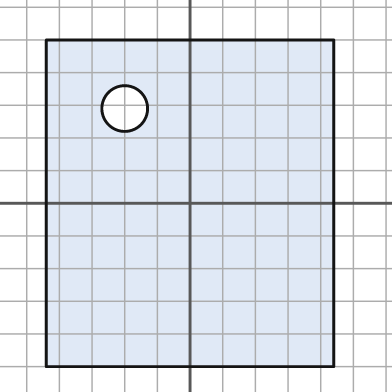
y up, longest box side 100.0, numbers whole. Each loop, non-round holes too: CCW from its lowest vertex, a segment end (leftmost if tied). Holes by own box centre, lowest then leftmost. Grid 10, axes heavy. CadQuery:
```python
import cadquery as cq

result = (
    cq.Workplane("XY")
    .moveTo(-44.0, -50.0)
    .lineTo(44.0, -50.0)
    .lineTo(44.0, 50.0)
    .lineTo(-44.0, 50.0)
    .close()
    .moveTo(-20.0, 29.0)
    .circle(7.0)
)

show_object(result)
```